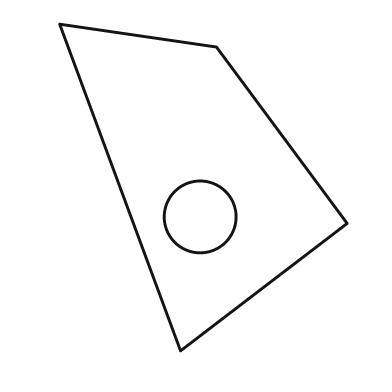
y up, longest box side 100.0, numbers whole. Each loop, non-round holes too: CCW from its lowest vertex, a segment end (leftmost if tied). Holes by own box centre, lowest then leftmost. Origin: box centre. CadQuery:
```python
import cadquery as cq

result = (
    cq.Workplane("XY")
    .moveTo(-7.0, -50.0)
    .lineTo(44.0, -11.0)
    .lineTo(4.0, 43.0)
    .lineTo(-44.0, 50.0)
    .close()
    .moveTo(-1.0, -9.0)
    .circle(11.0)
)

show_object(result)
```